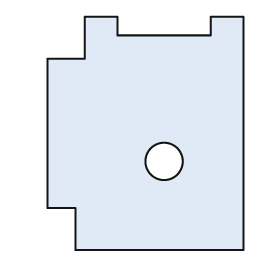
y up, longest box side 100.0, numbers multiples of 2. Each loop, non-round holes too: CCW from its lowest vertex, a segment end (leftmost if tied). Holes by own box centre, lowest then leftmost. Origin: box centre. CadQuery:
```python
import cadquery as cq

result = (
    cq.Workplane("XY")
    .moveTo(-30.0, -50.0)
    .lineTo(42.0, -50.0)
    .lineTo(42.0, 50.0)
    .lineTo(28.0, 50.0)
    .lineTo(28.0, 42.0)
    .lineTo(-12.0, 42.0)
    .lineTo(-12.0, 50.0)
    .lineTo(-26.0, 50.0)
    .lineTo(-26.0, 32.0)
    .lineTo(-42.0, 32.0)
    .lineTo(-42.0, -32.0)
    .lineTo(-30.0, -32.0)
    .close()
    .moveTo(8.0, -12.0)
    .circle(8.0)
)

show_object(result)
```